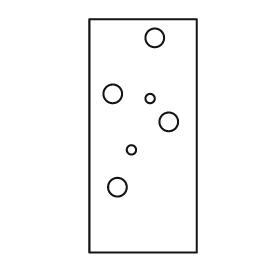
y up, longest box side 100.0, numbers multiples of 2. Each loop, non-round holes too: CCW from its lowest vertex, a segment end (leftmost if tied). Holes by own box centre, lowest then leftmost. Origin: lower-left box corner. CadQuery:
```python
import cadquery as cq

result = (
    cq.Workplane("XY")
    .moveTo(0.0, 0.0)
    .lineTo(46.0, 0.0)
    .lineTo(46.0, 100.0)
    .lineTo(0.0, 100.0)
    .close()
    .moveTo(12.0, 28.0)
    .circle(4.0)
    .moveTo(18.0, 44.0)
    .circle(2.0)
    .moveTo(34.0, 56.0)
    .circle(4.0)
    .moveTo(26.0, 66.0)
    .circle(2.0)
    .moveTo(10.0, 68.0)
    .circle(4.0)
    .moveTo(28.0, 92.0)
    .circle(4.0)
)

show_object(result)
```